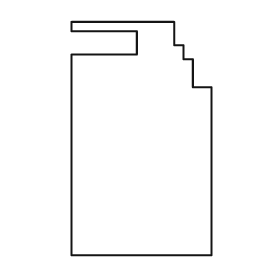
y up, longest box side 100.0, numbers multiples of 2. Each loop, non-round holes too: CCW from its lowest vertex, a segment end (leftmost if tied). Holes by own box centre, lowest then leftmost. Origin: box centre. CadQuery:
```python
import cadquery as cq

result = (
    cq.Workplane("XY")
    .moveTo(-30.0, -50.0)
    .lineTo(30.0, -50.0)
    .lineTo(30.0, 22.0)
    .lineTo(22.0, 22.0)
    .lineTo(22.0, 34.0)
    .lineTo(18.0, 34.0)
    .lineTo(18.0, 40.0)
    .lineTo(14.0, 40.0)
    .lineTo(14.0, 50.0)
    .lineTo(-30.0, 50.0)
    .lineTo(-30.0, 46.0)
    .lineTo(-2.0, 46.0)
    .lineTo(-2.0, 36.0)
    .lineTo(-30.0, 36.0)
    .close()
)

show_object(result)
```